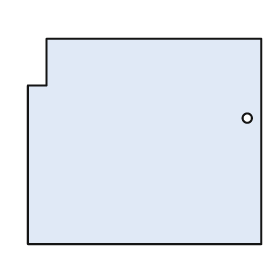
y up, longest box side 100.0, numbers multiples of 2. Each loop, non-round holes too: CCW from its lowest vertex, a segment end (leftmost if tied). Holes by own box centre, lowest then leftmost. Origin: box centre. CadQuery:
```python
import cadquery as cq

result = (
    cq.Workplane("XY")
    .moveTo(-50.0, -44.0)
    .lineTo(50.0, -44.0)
    .lineTo(50.0, 44.0)
    .lineTo(-42.0, 44.0)
    .lineTo(-42.0, 24.0)
    .lineTo(-50.0, 24.0)
    .close()
    .moveTo(44.0, 10.0)
    .circle(2.0)
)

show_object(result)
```